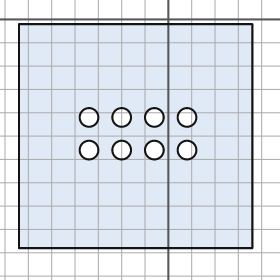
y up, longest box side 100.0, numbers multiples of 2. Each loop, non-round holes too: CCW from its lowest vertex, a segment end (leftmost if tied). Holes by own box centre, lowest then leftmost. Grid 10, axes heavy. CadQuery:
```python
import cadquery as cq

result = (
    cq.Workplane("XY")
    .moveTo(-64.0, -98.0)
    .lineTo(36.0, -98.0)
    .lineTo(36.0, -2.0)
    .lineTo(-64.0, -2.0)
    .close()
    .moveTo(-34.0, -56.0)
    .circle(4.0)
    .moveTo(-20.0, -56.0)
    .circle(4.0)
    .moveTo(-6.0, -56.0)
    .circle(4.0)
    .moveTo(8.0, -56.0)
    .circle(4.0)
    .moveTo(-34.0, -42.0)
    .circle(4.0)
    .moveTo(-20.0, -42.0)
    .circle(4.0)
    .moveTo(-6.0, -42.0)
    .circle(4.0)
    .moveTo(8.0, -42.0)
    .circle(4.0)
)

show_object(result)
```